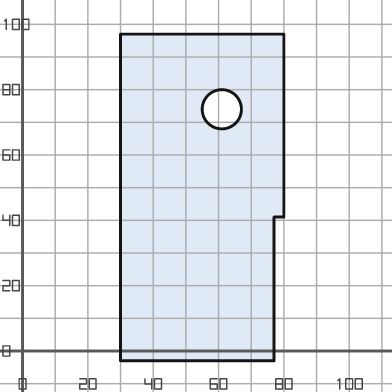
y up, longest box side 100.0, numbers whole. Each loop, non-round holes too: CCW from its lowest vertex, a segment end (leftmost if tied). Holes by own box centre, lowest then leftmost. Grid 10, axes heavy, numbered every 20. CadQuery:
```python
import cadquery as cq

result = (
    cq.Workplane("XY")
    .moveTo(30.0, -3.0)
    .lineTo(77.0, -3.0)
    .lineTo(77.0, 41.0)
    .lineTo(80.0, 41.0)
    .lineTo(80.0, 97.0)
    .lineTo(30.0, 97.0)
    .close()
    .moveTo(61.0, 74.0)
    .circle(6.0)
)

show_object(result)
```